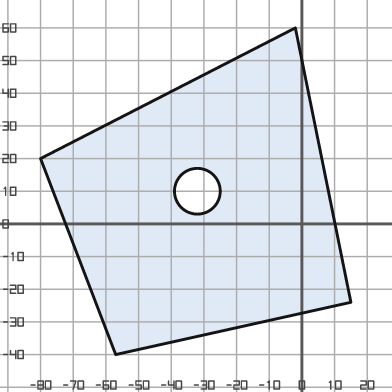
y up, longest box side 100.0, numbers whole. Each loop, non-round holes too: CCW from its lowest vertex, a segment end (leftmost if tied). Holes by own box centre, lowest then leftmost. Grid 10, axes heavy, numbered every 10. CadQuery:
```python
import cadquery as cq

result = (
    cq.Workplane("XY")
    .moveTo(-57.0, -40.0)
    .lineTo(15.0, -24.0)
    .lineTo(-2.0, 60.0)
    .lineTo(-80.0, 20.0)
    .close()
    .moveTo(-32.0, 10.0)
    .circle(7.0)
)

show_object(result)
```